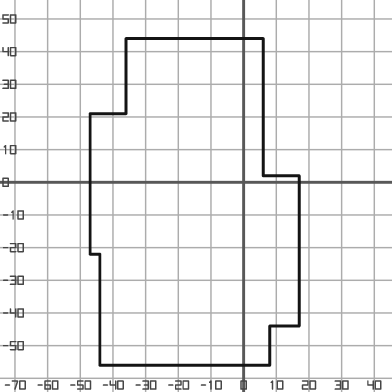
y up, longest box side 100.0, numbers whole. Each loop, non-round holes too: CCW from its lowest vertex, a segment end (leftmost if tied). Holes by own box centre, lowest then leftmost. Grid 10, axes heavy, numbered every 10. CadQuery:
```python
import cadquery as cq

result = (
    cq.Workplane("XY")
    .moveTo(-44.0, -56.0)
    .lineTo(8.0, -56.0)
    .lineTo(8.0, -44.0)
    .lineTo(17.0, -44.0)
    .lineTo(17.0, 2.0)
    .lineTo(6.0, 2.0)
    .lineTo(6.0, 44.0)
    .lineTo(-36.0, 44.0)
    .lineTo(-36.0, 21.0)
    .lineTo(-47.0, 21.0)
    .lineTo(-47.0, -22.0)
    .lineTo(-44.0, -22.0)
    .close()
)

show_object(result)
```